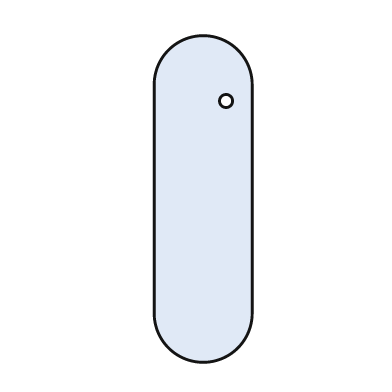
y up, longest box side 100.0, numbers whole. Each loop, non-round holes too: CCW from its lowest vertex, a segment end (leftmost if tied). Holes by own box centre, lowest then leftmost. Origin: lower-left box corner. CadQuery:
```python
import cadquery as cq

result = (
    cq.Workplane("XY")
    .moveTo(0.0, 15.0)
    .threePointArc((15.0, 0.0), (30.0, 15.0))
    .lineTo(30.0, 85.0)
    .threePointArc((15.0, 100.0), (0.0, 85.0))
    .close()
    .moveTo(22.0, 80.0)
    .circle(2.0)
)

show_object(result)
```